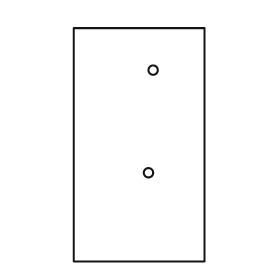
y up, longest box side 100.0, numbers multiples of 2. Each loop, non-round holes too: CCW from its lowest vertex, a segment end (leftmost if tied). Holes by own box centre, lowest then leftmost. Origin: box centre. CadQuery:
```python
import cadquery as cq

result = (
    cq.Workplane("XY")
    .moveTo(-28.0, -50.0)
    .lineTo(28.0, -50.0)
    .lineTo(28.0, 50.0)
    .lineTo(-28.0, 50.0)
    .close()
    .moveTo(4.0, -12.0)
    .circle(2.0)
    .moveTo(6.0, 32.0)
    .circle(2.0)
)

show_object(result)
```